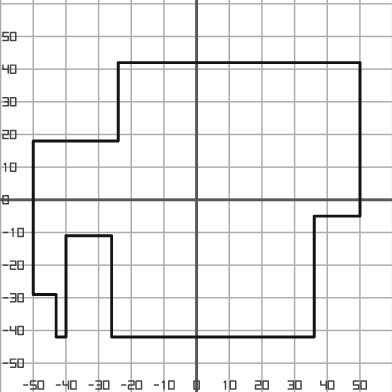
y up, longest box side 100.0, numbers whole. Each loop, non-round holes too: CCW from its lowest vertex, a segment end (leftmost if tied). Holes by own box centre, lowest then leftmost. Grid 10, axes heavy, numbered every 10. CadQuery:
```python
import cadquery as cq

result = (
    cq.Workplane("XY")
    .moveTo(-43.0, -42.0)
    .lineTo(-40.0, -42.0)
    .lineTo(-40.0, -11.0)
    .lineTo(-26.0, -11.0)
    .lineTo(-26.0, -42.0)
    .lineTo(36.0, -42.0)
    .lineTo(36.0, -5.0)
    .lineTo(50.0, -5.0)
    .lineTo(50.0, 42.0)
    .lineTo(-24.0, 42.0)
    .lineTo(-24.0, 18.0)
    .lineTo(-50.0, 18.0)
    .lineTo(-50.0, -29.0)
    .lineTo(-43.0, -29.0)
    .close()
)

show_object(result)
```